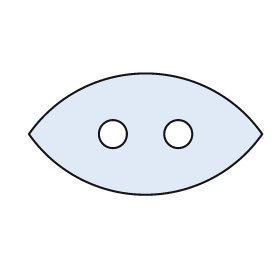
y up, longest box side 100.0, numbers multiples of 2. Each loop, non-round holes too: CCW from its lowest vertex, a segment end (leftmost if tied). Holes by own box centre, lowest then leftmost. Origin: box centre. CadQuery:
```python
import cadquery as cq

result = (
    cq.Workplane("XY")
    .moveTo(-50.0, 0.0)
    .threePointArc((0.0, -26.0), (50.0, 0.0))
    .threePointArc((0.0, 26.0), (-50.0, 0.0))
    .close()
    .moveTo(-14.0, 0.0)
    .circle(6.0)
    .moveTo(14.0, 0.0)
    .circle(6.0)
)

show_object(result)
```